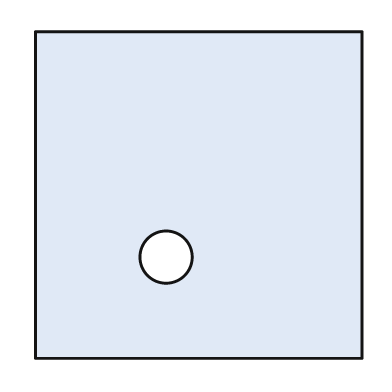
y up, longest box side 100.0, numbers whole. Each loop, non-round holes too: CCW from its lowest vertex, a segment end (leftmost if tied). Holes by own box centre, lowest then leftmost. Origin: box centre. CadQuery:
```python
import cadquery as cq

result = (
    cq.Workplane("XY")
    .moveTo(-50.0, -50.0)
    .lineTo(50.0, -50.0)
    .lineTo(50.0, 50.0)
    .lineTo(-50.0, 50.0)
    .close()
    .moveTo(-10.0, -19.0)
    .circle(8.0)
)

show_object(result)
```